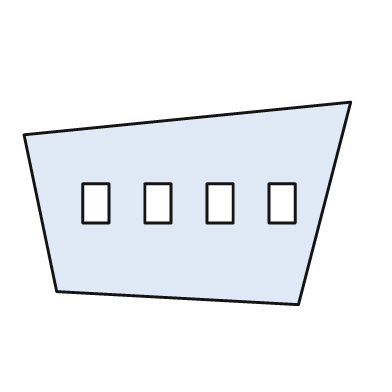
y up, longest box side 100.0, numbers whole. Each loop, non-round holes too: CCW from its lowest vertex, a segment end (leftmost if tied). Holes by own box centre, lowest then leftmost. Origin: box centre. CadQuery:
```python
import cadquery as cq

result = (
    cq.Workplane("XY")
    .moveTo(34.0, -31.0)
    .lineTo(50.0, 31.0)
    .lineTo(-50.0, 21.0)
    .lineTo(-40.0, -27.0)
    .close()
    .moveTo(-32.0, -6.0)
    .lineTo(-24.0, -6.0)
    .lineTo(-24.0, 6.0)
    .lineTo(-32.0, 6.0)
    .close()
    .moveTo(-13.0, -6.0)
    .lineTo(-5.0, -6.0)
    .lineTo(-5.0, 6.0)
    .lineTo(-13.0, 6.0)
    .close()
    .moveTo(6.0, -6.0)
    .lineTo(14.0, -6.0)
    .lineTo(14.0, 6.0)
    .lineTo(6.0, 6.0)
    .close()
    .moveTo(25.0, -6.0)
    .lineTo(33.0, -6.0)
    .lineTo(33.0, 6.0)
    .lineTo(25.0, 6.0)
    .close()
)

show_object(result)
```